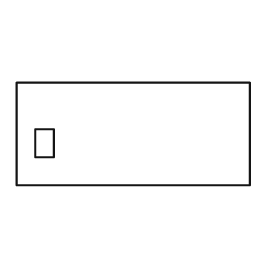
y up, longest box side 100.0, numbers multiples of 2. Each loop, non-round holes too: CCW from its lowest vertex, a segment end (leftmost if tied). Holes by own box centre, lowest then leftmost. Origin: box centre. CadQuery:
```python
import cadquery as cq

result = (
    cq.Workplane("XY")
    .moveTo(-50.0, -22.0)
    .lineTo(50.0, -22.0)
    .lineTo(50.0, 22.0)
    .lineTo(-50.0, 22.0)
    .close()
    .moveTo(-42.0, -10.0)
    .lineTo(-34.0, -10.0)
    .lineTo(-34.0, 2.0)
    .lineTo(-42.0, 2.0)
    .close()
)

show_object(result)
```